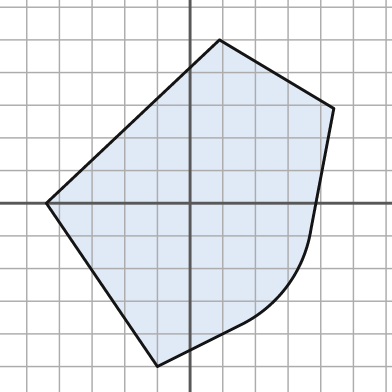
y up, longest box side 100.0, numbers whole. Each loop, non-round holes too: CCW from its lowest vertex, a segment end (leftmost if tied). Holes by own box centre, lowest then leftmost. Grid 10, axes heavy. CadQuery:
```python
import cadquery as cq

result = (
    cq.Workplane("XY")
    .moveTo(-10.0, -50.0)
    .lineTo(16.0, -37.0)
    .threePointArc((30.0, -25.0), (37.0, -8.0))
    .lineTo(44.0, 29.0)
    .lineTo(9.0, 50.0)
    .lineTo(-44.0, 0.0)
    .close()
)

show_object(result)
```